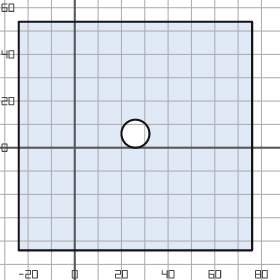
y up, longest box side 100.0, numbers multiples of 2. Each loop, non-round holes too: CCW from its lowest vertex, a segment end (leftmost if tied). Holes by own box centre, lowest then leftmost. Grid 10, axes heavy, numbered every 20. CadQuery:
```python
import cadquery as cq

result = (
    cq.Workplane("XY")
    .moveTo(-24.0, -44.0)
    .lineTo(76.0, -44.0)
    .lineTo(76.0, 54.0)
    .lineTo(-24.0, 54.0)
    .close()
    .moveTo(26.0, 6.0)
    .circle(6.0)
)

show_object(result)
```